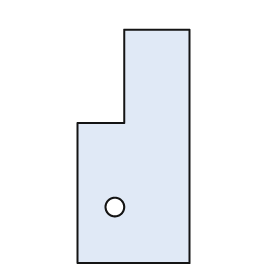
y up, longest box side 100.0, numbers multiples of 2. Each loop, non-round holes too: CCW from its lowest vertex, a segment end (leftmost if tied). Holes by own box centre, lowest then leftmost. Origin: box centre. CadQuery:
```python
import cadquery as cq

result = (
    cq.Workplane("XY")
    .moveTo(-24.0, -50.0)
    .lineTo(24.0, -50.0)
    .lineTo(24.0, 50.0)
    .lineTo(-4.0, 50.0)
    .lineTo(-4.0, 10.0)
    .lineTo(-24.0, 10.0)
    .close()
    .moveTo(-8.0, -26.0)
    .circle(4.0)
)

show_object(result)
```